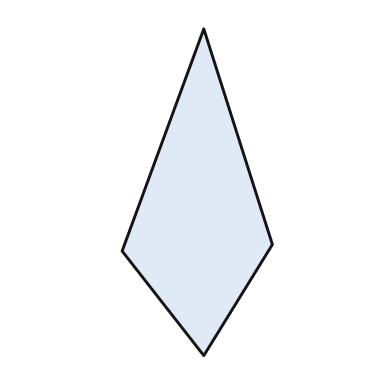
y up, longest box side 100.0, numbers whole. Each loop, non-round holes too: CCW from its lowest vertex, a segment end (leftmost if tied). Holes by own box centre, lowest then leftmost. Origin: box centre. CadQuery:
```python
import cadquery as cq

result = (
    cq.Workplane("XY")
    .moveTo(2.0, -50.0)
    .lineTo(23.0, -16.0)
    .lineTo(2.0, 50.0)
    .lineTo(-23.0, -18.0)
    .close()
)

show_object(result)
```